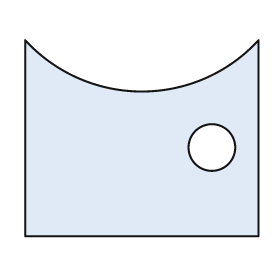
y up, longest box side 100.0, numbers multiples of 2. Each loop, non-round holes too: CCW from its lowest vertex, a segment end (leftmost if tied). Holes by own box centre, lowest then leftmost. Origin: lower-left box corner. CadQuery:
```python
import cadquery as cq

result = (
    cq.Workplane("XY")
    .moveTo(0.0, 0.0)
    .lineTo(100.0, 0.0)
    .lineTo(100.0, 84.0)
    .threePointArc((50.0, 62.0), (0.0, 84.0))
    .close()
    .moveTo(80.0, 38.0)
    .circle(10.0)
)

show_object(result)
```